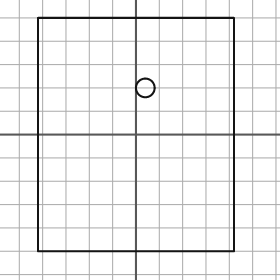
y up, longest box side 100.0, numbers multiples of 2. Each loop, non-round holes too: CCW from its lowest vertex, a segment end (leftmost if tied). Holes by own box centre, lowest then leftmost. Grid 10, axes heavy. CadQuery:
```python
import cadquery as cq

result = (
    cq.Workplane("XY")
    .moveTo(-42.0, -50.0)
    .lineTo(42.0, -50.0)
    .lineTo(42.0, 50.0)
    .lineTo(-42.0, 50.0)
    .close()
    .moveTo(4.0, 20.0)
    .circle(4.0)
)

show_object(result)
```